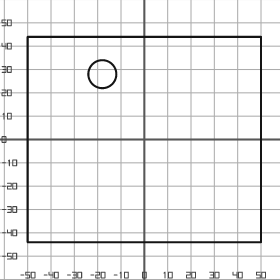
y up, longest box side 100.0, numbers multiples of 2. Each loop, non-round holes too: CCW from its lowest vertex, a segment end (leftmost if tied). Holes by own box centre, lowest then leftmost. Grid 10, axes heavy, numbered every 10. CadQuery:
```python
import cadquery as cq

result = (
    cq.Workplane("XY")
    .moveTo(-50.0, -44.0)
    .lineTo(50.0, -44.0)
    .lineTo(50.0, 44.0)
    .lineTo(-50.0, 44.0)
    .close()
    .moveTo(-18.0, 28.0)
    .circle(6.0)
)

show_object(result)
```